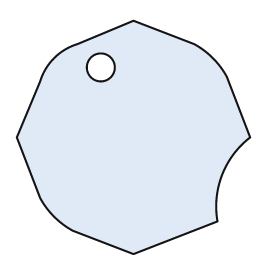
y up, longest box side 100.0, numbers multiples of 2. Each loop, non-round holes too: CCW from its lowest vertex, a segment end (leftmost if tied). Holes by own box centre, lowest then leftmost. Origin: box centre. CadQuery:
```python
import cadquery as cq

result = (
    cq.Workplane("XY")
    .moveTo(0.0, -50.0)
    .lineTo(36.0, -36.0)
    .threePointArc((38.0, -16.0), (50.0, 0.0))
    .lineTo(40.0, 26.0)
    .threePointArc((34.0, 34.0), (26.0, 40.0))
    .lineTo(0.0, 50.0)
    .lineTo(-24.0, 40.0)
    .threePointArc((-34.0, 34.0), (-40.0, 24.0))
    .lineTo(-50.0, 0.0)
    .lineTo(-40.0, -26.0)
    .threePointArc((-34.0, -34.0), (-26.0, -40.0))
    .close()
    .moveTo(-14.0, 30.0)
    .circle(6.0)
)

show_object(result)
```